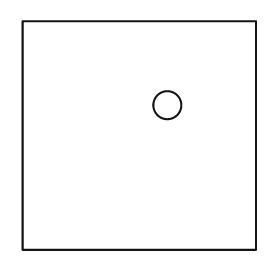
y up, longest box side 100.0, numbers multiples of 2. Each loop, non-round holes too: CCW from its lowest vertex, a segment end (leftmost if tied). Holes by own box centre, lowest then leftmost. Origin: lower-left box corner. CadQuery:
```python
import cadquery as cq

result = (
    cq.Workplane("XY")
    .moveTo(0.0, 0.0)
    .lineTo(100.0, 0.0)
    .lineTo(100.0, 98.0)
    .lineTo(0.0, 98.0)
    .close()
    .moveTo(62.0, 62.0)
    .circle(6.0)
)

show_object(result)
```